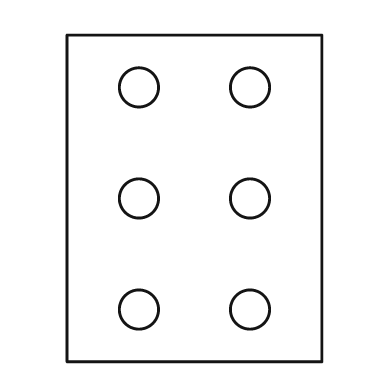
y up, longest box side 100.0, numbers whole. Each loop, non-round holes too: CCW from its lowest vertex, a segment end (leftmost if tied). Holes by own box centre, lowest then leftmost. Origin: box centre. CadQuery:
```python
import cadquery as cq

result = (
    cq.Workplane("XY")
    .moveTo(-39.0, -50.0)
    .lineTo(39.0, -50.0)
    .lineTo(39.0, 50.0)
    .lineTo(-39.0, 50.0)
    .close()
    .moveTo(-17.0, -34.0)
    .circle(6.0)
    .moveTo(17.0, -34.0)
    .circle(6.0)
    .moveTo(-17.0, 0.0)
    .circle(6.0)
    .moveTo(17.0, 0.0)
    .circle(6.0)
    .moveTo(-17.0, 34.0)
    .circle(6.0)
    .moveTo(17.0, 34.0)
    .circle(6.0)
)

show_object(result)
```